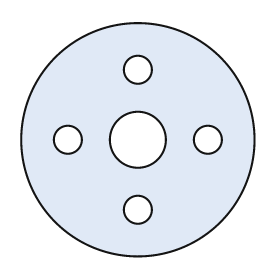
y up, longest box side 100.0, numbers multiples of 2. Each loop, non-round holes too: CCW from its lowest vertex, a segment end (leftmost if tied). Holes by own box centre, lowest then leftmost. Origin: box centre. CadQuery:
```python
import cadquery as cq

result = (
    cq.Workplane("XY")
    .moveTo(0.0, 0.0)
    .circle(50.0)
    .moveTo(0.0, -30.0)
    .circle(6.0)
    .moveTo(-30.0, 0.0)
    .circle(6.0)
    .moveTo(0.0, 0.0)
    .circle(12.0)
    .moveTo(30.0, 0.0)
    .circle(6.0)
    .moveTo(0.0, 30.0)
    .circle(6.0)
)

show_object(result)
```